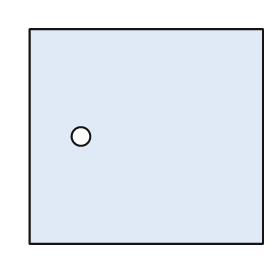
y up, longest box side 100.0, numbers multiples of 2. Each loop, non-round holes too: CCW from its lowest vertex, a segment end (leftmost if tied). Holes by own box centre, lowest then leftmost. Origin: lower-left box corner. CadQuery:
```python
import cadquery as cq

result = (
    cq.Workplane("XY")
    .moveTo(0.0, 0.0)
    .lineTo(100.0, 0.0)
    .lineTo(100.0, 92.0)
    .lineTo(0.0, 92.0)
    .close()
    .moveTo(22.0, 46.0)
    .circle(4.0)
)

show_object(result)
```